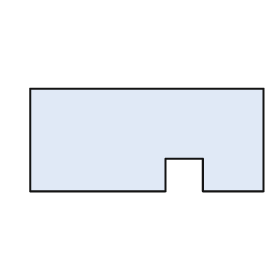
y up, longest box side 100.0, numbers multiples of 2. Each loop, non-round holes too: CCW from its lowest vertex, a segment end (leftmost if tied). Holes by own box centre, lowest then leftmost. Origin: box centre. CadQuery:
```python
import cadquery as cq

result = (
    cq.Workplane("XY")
    .moveTo(-50.0, -22.0)
    .lineTo(8.0, -22.0)
    .lineTo(8.0, -8.0)
    .lineTo(24.0, -8.0)
    .lineTo(24.0, -22.0)
    .lineTo(50.0, -22.0)
    .lineTo(50.0, 22.0)
    .lineTo(-50.0, 22.0)
    .close()
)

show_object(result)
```